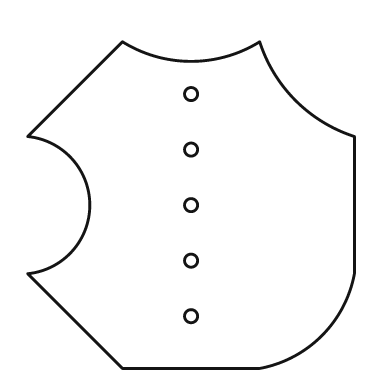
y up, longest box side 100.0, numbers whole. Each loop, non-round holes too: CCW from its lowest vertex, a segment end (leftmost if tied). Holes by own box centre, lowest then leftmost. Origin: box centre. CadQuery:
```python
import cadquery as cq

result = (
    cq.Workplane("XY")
    .moveTo(-21.0, -50.0)
    .lineTo(21.0, -50.0)
    .threePointArc((40.0, -40.0), (50.0, -21.0))
    .lineTo(50.0, 21.0)
    .threePointArc((32.0, 32.0), (21.0, 50.0))
    .threePointArc((0.0, 44.0), (-21.0, 50.0))
    .lineTo(-50.0, 21.0)
    .threePointArc((-31.0, 0.0), (-50.0, -21.0))
    .close()
    .moveTo(0.0, -34.0)
    .circle(2.0)
    .moveTo(0.0, -17.0)
    .circle(2.0)
    .moveTo(0.0, 0.0)
    .circle(2.0)
    .moveTo(0.0, 17.0)
    .circle(2.0)
    .moveTo(0.0, 34.0)
    .circle(2.0)
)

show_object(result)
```